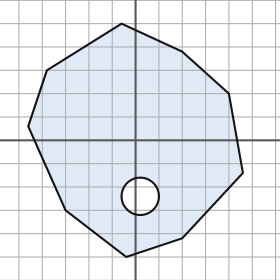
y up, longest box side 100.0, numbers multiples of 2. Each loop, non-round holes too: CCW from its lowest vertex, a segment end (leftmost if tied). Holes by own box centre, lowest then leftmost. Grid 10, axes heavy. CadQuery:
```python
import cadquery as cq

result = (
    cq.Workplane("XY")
    .moveTo(-4.0, -50.0)
    .lineTo(20.0, -42.0)
    .lineTo(46.0, -14.0)
    .lineTo(40.0, 20.0)
    .lineTo(20.0, 38.0)
    .lineTo(-6.0, 50.0)
    .lineTo(-38.0, 30.0)
    .lineTo(-46.0, 6.0)
    .lineTo(-30.0, -30.0)
    .close()
    .moveTo(2.0, -24.0)
    .circle(8.0)
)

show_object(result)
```